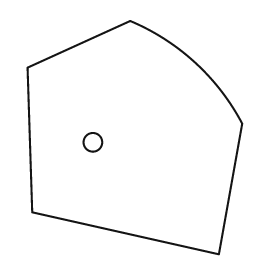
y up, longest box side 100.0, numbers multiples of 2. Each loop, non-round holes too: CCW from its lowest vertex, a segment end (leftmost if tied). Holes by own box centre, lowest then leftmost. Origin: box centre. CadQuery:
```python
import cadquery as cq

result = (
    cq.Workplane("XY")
    .moveTo(36.0, -50.0)
    .lineTo(46.0, 6.0)
    .threePointArc((26.0, 32.0), (-2.0, 50.0))
    .lineTo(-46.0, 30.0)
    .lineTo(-44.0, -32.0)
    .close()
    .moveTo(-18.0, -2.0)
    .circle(4.0)
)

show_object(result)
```